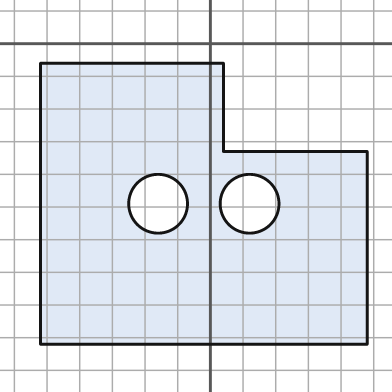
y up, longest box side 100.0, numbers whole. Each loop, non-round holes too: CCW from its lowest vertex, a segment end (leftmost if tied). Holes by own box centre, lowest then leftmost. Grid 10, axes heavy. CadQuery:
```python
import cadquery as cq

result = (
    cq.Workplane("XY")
    .moveTo(-52.0, -92.0)
    .lineTo(48.0, -92.0)
    .lineTo(48.0, -33.0)
    .lineTo(4.0, -33.0)
    .lineTo(4.0, -6.0)
    .lineTo(-52.0, -6.0)
    .close()
    .moveTo(-16.0, -49.0)
    .circle(9.0)
    .moveTo(12.0, -49.0)
    .circle(9.0)
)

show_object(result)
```